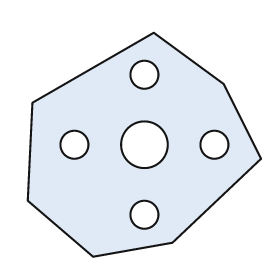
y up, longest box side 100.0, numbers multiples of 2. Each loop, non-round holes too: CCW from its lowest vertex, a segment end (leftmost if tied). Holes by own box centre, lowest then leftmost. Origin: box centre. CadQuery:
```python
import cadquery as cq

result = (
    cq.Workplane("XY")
    .moveTo(-22.0, -48.0)
    .lineTo(12.0, -42.0)
    .lineTo(50.0, -6.0)
    .lineTo(34.0, 26.0)
    .lineTo(4.0, 48.0)
    .lineTo(-48.0, 18.0)
    .lineTo(-50.0, -24.0)
    .close()
    .moveTo(0.0, -30.0)
    .circle(6.0)
    .moveTo(-30.0, 0.0)
    .circle(6.0)
    .moveTo(0.0, 0.0)
    .circle(10.0)
    .moveTo(30.0, 0.0)
    .circle(6.0)
    .moveTo(0.0, 30.0)
    .circle(6.0)
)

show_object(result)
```